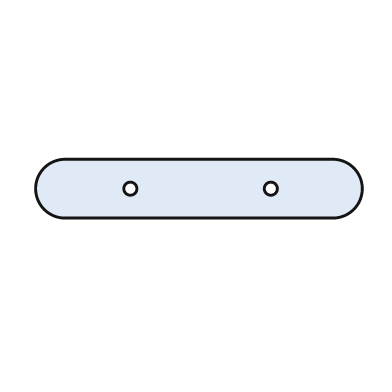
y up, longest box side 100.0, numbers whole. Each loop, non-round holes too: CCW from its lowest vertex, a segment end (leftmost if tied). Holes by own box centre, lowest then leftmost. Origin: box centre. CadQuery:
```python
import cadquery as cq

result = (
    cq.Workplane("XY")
    .moveTo(-41.0, -9.0)
    .lineTo(41.0, -9.0)
    .threePointArc((50.0, 0.0), (41.0, 9.0))
    .lineTo(-41.0, 9.0)
    .threePointArc((-50.0, 0.0), (-41.0, -9.0))
    .close()
    .moveTo(-21.0, 0.0)
    .circle(2.0)
    .moveTo(22.0, 0.0)
    .circle(2.0)
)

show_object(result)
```